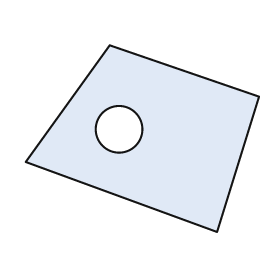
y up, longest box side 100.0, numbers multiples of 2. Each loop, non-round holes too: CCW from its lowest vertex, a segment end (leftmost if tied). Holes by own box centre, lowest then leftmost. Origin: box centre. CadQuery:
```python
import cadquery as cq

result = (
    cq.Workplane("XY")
    .moveTo(32.0, -40.0)
    .lineTo(50.0, 18.0)
    .lineTo(-14.0, 40.0)
    .lineTo(-50.0, -10.0)
    .close()
    .moveTo(-10.0, 4.0)
    .circle(10.0)
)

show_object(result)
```